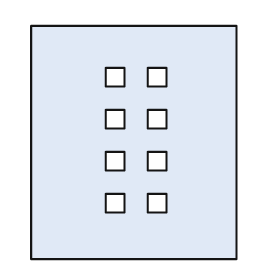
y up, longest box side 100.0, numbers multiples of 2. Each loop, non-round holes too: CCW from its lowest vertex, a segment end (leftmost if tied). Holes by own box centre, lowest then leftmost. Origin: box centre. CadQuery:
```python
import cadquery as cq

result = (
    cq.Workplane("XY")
    .moveTo(-44.0, -50.0)
    .lineTo(44.0, -50.0)
    .lineTo(44.0, 50.0)
    .lineTo(-44.0, 50.0)
    .close()
    .moveTo(-12.0, -30.0)
    .lineTo(-4.0, -30.0)
    .lineTo(-4.0, -22.0)
    .lineTo(-12.0, -22.0)
    .close()
    .moveTo(6.0, -30.0)
    .lineTo(14.0, -30.0)
    .lineTo(14.0, -22.0)
    .lineTo(6.0, -22.0)
    .close()
    .moveTo(-12.0, -12.0)
    .lineTo(-4.0, -12.0)
    .lineTo(-4.0, -4.0)
    .lineTo(-12.0, -4.0)
    .close()
    .moveTo(6.0, -12.0)
    .lineTo(14.0, -12.0)
    .lineTo(14.0, -4.0)
    .lineTo(6.0, -4.0)
    .close()
    .moveTo(-12.0, 6.0)
    .lineTo(-4.0, 6.0)
    .lineTo(-4.0, 14.0)
    .lineTo(-12.0, 14.0)
    .close()
    .moveTo(6.0, 6.0)
    .lineTo(14.0, 6.0)
    .lineTo(14.0, 14.0)
    .lineTo(6.0, 14.0)
    .close()
    .moveTo(-12.0, 24.0)
    .lineTo(-4.0, 24.0)
    .lineTo(-4.0, 32.0)
    .lineTo(-12.0, 32.0)
    .close()
    .moveTo(6.0, 24.0)
    .lineTo(14.0, 24.0)
    .lineTo(14.0, 32.0)
    .lineTo(6.0, 32.0)
    .close()
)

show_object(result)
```